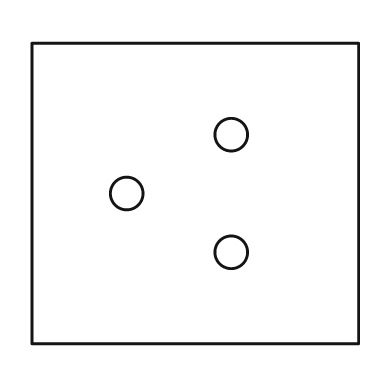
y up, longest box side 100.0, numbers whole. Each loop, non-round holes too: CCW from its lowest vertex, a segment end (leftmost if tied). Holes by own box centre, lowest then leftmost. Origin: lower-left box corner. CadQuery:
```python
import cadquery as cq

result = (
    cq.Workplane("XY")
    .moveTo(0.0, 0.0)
    .lineTo(100.0, 0.0)
    .lineTo(100.0, 92.0)
    .lineTo(0.0, 92.0)
    .close()
    .moveTo(61.0, 28.0)
    .circle(5.0)
    .moveTo(29.0, 46.0)
    .circle(5.0)
    .moveTo(61.0, 64.0)
    .circle(5.0)
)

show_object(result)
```